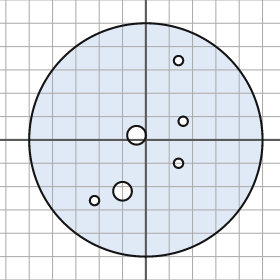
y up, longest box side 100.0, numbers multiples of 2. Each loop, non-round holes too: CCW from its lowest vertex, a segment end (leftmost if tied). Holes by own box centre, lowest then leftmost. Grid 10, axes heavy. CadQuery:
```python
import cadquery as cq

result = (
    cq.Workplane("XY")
    .moveTo(0.0, 0.0)
    .circle(50.0)
    .moveTo(-22.0, -26.0)
    .circle(2.0)
    .moveTo(-10.0, -22.0)
    .circle(4.0)
    .moveTo(14.0, -10.0)
    .circle(2.0)
    .moveTo(-4.0, 2.0)
    .circle(4.0)
    .moveTo(16.0, 8.0)
    .circle(2.0)
    .moveTo(14.0, 34.0)
    .circle(2.0)
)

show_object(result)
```